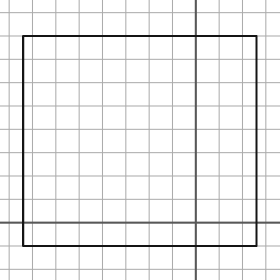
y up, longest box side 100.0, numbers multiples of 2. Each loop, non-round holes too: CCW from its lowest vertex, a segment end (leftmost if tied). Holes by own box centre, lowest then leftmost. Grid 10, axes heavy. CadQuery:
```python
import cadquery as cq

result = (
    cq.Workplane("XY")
    .moveTo(-74.0, -10.0)
    .lineTo(26.0, -10.0)
    .lineTo(26.0, 80.0)
    .lineTo(-74.0, 80.0)
    .close()
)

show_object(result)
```